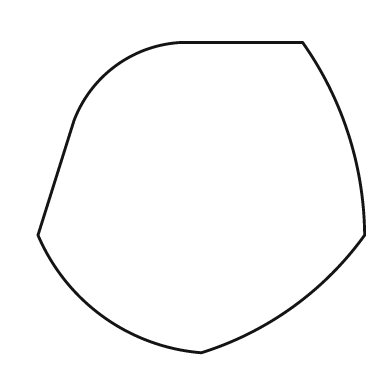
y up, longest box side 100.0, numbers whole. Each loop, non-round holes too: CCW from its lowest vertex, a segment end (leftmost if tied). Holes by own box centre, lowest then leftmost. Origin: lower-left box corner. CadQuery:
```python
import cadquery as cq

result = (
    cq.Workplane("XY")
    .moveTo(50.0, 0.0)
    .threePointArc((78.0, 14.0), (100.0, 36.0))
    .threePointArc((95.0, 67.0), (81.0, 95.0))
    .lineTo(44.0, 95.0)
    .threePointArc((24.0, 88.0), (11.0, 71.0))
    .lineTo(0.0, 36.0)
    .threePointArc((20.0, 11.0), (50.0, 0.0))
    .close()
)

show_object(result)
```